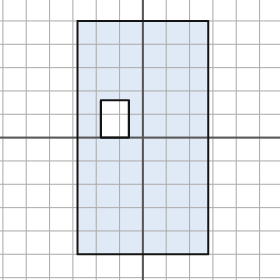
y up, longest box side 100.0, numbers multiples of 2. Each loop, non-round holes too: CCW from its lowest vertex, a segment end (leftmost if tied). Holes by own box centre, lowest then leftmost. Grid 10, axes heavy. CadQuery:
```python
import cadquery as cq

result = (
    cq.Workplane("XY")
    .moveTo(-28.0, -50.0)
    .lineTo(28.0, -50.0)
    .lineTo(28.0, 50.0)
    .lineTo(-28.0, 50.0)
    .close()
    .moveTo(-18.0, 0.0)
    .lineTo(-6.0, 0.0)
    .lineTo(-6.0, 16.0)
    .lineTo(-18.0, 16.0)
    .close()
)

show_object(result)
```